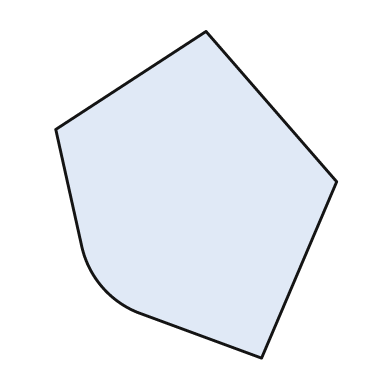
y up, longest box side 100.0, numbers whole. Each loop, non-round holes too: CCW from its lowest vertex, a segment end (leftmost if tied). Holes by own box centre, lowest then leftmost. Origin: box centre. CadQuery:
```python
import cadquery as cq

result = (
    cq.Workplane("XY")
    .moveTo(20.0, -50.0)
    .lineTo(43.0, 4.0)
    .lineTo(3.0, 50.0)
    .lineTo(-43.0, 20.0)
    .lineTo(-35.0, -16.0)
    .threePointArc((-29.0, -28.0), (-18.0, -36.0))
    .close()
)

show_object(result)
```